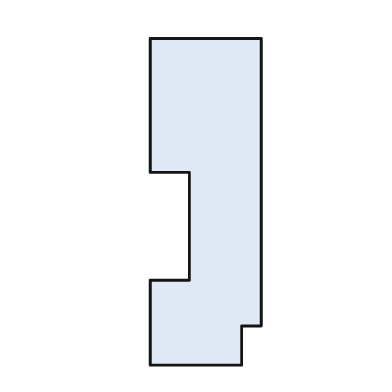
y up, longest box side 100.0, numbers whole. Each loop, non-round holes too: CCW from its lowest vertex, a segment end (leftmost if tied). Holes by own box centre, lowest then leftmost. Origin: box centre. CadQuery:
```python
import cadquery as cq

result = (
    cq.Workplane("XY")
    .moveTo(-17.0, -50.0)
    .lineTo(11.0, -50.0)
    .lineTo(11.0, -38.0)
    .lineTo(17.0, -38.0)
    .lineTo(17.0, 50.0)
    .lineTo(-17.0, 50.0)
    .lineTo(-17.0, 9.0)
    .lineTo(-5.0, 9.0)
    .lineTo(-5.0, -24.0)
    .lineTo(-17.0, -24.0)
    .close()
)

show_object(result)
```